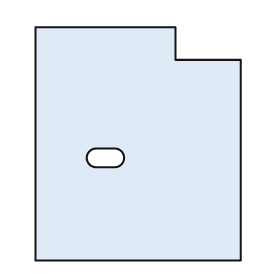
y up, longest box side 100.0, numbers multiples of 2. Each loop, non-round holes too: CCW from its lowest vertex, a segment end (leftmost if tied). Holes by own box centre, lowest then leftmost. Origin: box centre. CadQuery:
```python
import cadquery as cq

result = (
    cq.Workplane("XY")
    .moveTo(-44.0, -50.0)
    .lineTo(44.0, -50.0)
    .lineTo(44.0, 36.0)
    .lineTo(16.0, 36.0)
    .lineTo(16.0, 50.0)
    .lineTo(-44.0, 50.0)
    .close()
    .moveTo(-18.0, -10.0)
    .lineTo(-10.0, -10.0)
    .threePointArc((-6.0, -6.0), (-10.0, -2.0))
    .lineTo(-18.0, -2.0)
    .threePointArc((-22.0, -6.0), (-18.0, -10.0))
    .close()
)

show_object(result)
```